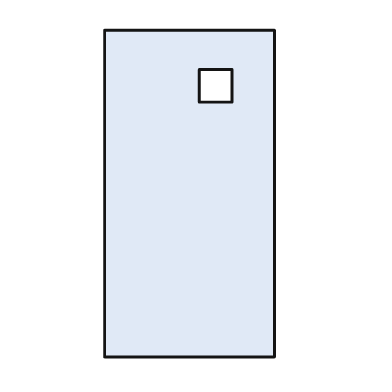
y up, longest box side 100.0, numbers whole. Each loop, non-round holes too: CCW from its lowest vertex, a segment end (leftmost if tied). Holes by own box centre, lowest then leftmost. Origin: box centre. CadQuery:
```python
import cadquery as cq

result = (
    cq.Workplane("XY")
    .moveTo(-26.0, -50.0)
    .lineTo(26.0, -50.0)
    .lineTo(26.0, 50.0)
    .lineTo(-26.0, 50.0)
    .close()
    .moveTo(3.0, 28.0)
    .lineTo(13.0, 28.0)
    .lineTo(13.0, 38.0)
    .lineTo(3.0, 38.0)
    .close()
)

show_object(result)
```